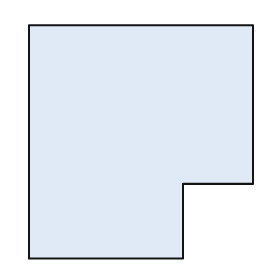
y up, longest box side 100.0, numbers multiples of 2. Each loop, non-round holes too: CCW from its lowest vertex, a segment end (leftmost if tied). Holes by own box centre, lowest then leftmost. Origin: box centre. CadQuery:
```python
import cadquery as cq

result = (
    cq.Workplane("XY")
    .moveTo(-48.0, -50.0)
    .lineTo(18.0, -50.0)
    .lineTo(18.0, -18.0)
    .lineTo(48.0, -18.0)
    .lineTo(48.0, 50.0)
    .lineTo(-48.0, 50.0)
    .close()
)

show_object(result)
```